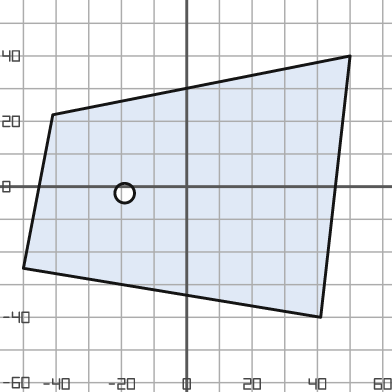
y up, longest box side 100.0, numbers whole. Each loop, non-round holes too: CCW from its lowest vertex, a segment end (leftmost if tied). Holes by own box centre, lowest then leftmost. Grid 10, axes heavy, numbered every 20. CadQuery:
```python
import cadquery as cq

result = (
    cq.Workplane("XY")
    .moveTo(41.0, -40.0)
    .lineTo(50.0, 40.0)
    .lineTo(-41.0, 22.0)
    .lineTo(-50.0, -25.0)
    .close()
    .moveTo(-19.0, -2.0)
    .circle(3.0)
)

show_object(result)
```